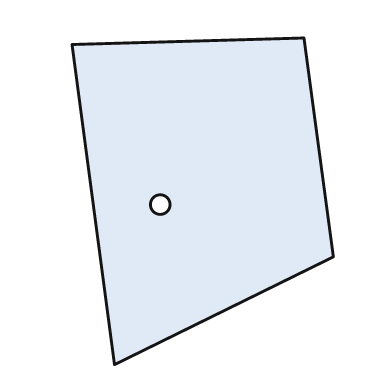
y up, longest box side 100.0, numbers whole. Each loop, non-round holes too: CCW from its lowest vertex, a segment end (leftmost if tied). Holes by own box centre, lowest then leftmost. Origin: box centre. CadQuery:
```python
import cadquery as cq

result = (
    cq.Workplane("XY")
    .moveTo(-27.0, -50.0)
    .lineTo(40.0, -17.0)
    .lineTo(31.0, 50.0)
    .lineTo(-40.0, 48.0)
    .close()
    .moveTo(-13.0, -1.0)
    .circle(3.0)
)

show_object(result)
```